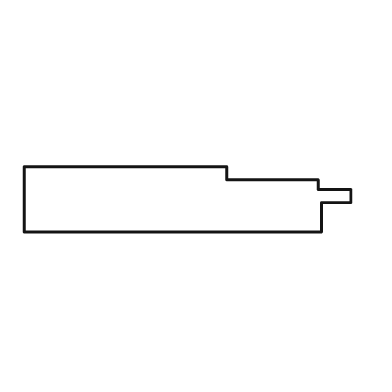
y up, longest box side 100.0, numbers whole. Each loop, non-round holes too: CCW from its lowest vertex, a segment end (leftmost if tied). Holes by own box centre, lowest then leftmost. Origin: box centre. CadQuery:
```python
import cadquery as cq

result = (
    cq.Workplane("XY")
    .moveTo(-50.0, -10.0)
    .lineTo(41.0, -10.0)
    .lineTo(41.0, -1.0)
    .lineTo(50.0, -1.0)
    .lineTo(50.0, 3.0)
    .lineTo(40.0, 3.0)
    .lineTo(40.0, 6.0)
    .lineTo(12.0, 6.0)
    .lineTo(12.0, 10.0)
    .lineTo(-50.0, 10.0)
    .close()
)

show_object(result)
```